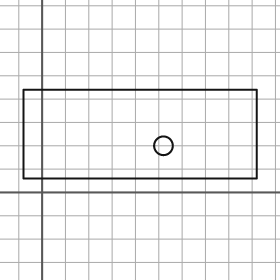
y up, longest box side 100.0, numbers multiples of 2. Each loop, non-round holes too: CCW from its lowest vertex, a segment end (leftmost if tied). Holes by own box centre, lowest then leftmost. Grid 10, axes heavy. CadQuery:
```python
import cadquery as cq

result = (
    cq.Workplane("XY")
    .moveTo(-8.0, 6.0)
    .lineTo(92.0, 6.0)
    .lineTo(92.0, 44.0)
    .lineTo(-8.0, 44.0)
    .close()
    .moveTo(52.0, 20.0)
    .circle(4.0)
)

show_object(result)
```